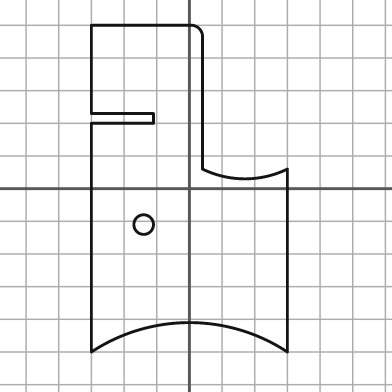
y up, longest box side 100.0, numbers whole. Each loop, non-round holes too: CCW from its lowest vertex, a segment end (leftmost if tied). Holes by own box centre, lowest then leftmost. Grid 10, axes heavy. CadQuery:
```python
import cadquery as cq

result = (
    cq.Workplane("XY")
    .moveTo(-30.0, -50.0)
    .threePointArc((0.0, -41.0), (30.0, -50.0))
    .lineTo(30.0, 6.0)
    .threePointArc((17.0, 3.0), (4.0, 6.0))
    .lineTo(4.0, 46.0)
    .threePointArc((3.0, 49.0), (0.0, 50.0))
    .lineTo(-30.0, 50.0)
    .lineTo(-30.0, 23.0)
    .lineTo(-11.0, 23.0)
    .lineTo(-11.0, 20.0)
    .lineTo(-30.0, 20.0)
    .close()
    .moveTo(-14.0, -11.0)
    .circle(3.0)
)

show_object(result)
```